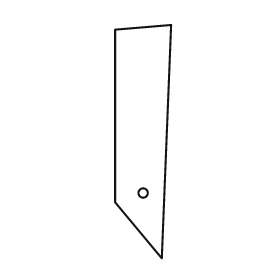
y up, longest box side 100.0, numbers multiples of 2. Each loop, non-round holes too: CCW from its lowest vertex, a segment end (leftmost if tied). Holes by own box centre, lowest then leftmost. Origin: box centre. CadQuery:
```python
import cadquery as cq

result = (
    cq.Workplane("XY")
    .moveTo(8.0, -50.0)
    .lineTo(12.0, 50.0)
    .lineTo(-12.0, 48.0)
    .lineTo(-12.0, -26.0)
    .close()
    .moveTo(0.0, -22.0)
    .circle(2.0)
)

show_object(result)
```